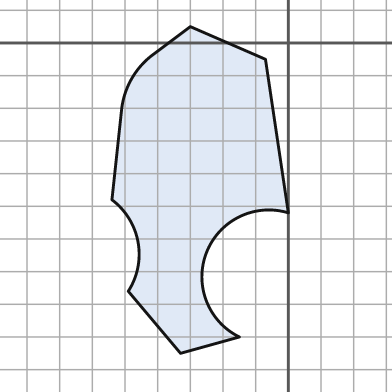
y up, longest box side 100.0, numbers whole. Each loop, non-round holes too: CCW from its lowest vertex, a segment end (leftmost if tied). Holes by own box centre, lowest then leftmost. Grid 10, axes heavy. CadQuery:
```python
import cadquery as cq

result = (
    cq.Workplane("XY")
    .moveTo(-33.0, -95.0)
    .lineTo(-15.0, -90.0)
    .threePointArc((-25.0, -64.0), (0.0, -52.0))
    .lineTo(-7.0, -5.0)
    .lineTo(-30.0, 5.0)
    .lineTo(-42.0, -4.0)
    .threePointArc((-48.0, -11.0), (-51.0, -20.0))
    .lineTo(-54.0, -48.0)
    .threePointArc((-46.0, -61.0), (-49.0, -76.0))
    .close()
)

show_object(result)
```